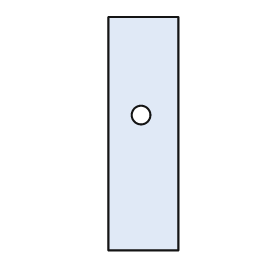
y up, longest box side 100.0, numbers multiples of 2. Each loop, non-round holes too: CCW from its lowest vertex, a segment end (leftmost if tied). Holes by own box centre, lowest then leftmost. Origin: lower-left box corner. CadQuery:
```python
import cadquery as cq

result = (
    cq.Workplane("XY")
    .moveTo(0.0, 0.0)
    .lineTo(30.0, 0.0)
    .lineTo(30.0, 100.0)
    .lineTo(0.0, 100.0)
    .close()
    .moveTo(14.0, 58.0)
    .circle(4.0)
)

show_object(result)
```